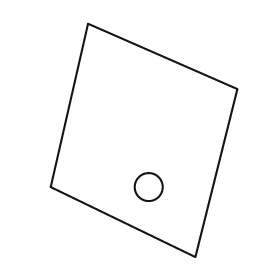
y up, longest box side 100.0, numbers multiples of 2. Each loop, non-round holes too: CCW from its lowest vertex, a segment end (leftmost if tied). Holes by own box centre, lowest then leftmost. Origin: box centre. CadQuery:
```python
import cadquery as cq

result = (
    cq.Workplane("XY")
    .moveTo(22.0, -50.0)
    .lineTo(40.0, 22.0)
    .lineTo(-24.0, 50.0)
    .lineTo(-40.0, -20.0)
    .close()
    .moveTo(2.0, -20.0)
    .circle(6.0)
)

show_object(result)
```